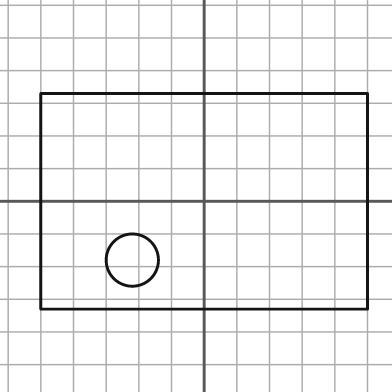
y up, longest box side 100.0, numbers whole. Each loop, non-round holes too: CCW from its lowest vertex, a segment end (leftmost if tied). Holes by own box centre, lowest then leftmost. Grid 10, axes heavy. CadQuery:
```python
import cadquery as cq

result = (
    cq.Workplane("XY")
    .moveTo(-50.0, -33.0)
    .lineTo(50.0, -33.0)
    .lineTo(50.0, 33.0)
    .lineTo(-50.0, 33.0)
    .close()
    .moveTo(-22.0, -18.0)
    .circle(8.0)
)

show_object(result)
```